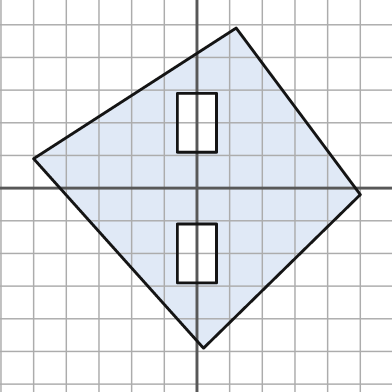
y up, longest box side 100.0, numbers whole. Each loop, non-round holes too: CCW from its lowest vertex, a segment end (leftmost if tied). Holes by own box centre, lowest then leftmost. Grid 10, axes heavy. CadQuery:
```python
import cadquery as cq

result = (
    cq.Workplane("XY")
    .moveTo(2.0, -49.0)
    .lineTo(50.0, -2.0)
    .lineTo(12.0, 49.0)
    .lineTo(-50.0, 9.0)
    .close()
    .moveTo(-6.0, -29.0)
    .lineTo(6.0, -29.0)
    .lineTo(6.0, -11.0)
    .lineTo(-6.0, -11.0)
    .close()
    .moveTo(-6.0, 11.0)
    .lineTo(6.0, 11.0)
    .lineTo(6.0, 29.0)
    .lineTo(-6.0, 29.0)
    .close()
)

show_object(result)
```